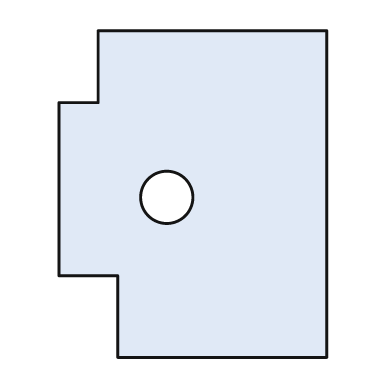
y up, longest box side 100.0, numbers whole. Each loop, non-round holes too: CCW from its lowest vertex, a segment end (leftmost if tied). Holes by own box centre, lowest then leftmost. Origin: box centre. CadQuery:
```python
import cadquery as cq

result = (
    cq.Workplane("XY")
    .moveTo(-23.0, -50.0)
    .lineTo(41.0, -50.0)
    .lineTo(41.0, 50.0)
    .lineTo(-29.0, 50.0)
    .lineTo(-29.0, 28.0)
    .lineTo(-41.0, 28.0)
    .lineTo(-41.0, -25.0)
    .lineTo(-23.0, -25.0)
    .close()
    .moveTo(-8.0, -1.0)
    .circle(8.0)
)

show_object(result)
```